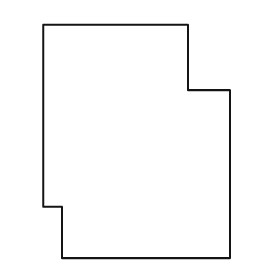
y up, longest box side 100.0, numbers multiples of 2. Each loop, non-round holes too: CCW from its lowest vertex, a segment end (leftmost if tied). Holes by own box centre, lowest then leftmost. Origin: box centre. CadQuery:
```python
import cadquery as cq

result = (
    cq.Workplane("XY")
    .moveTo(-32.0, -50.0)
    .lineTo(40.0, -50.0)
    .lineTo(40.0, 22.0)
    .lineTo(22.0, 22.0)
    .lineTo(22.0, 50.0)
    .lineTo(-40.0, 50.0)
    .lineTo(-40.0, -28.0)
    .lineTo(-32.0, -28.0)
    .close()
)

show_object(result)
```